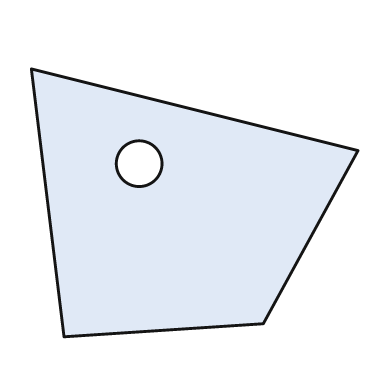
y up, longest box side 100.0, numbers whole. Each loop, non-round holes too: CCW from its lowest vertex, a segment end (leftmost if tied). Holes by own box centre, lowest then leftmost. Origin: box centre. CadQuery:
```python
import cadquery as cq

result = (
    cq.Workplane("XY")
    .moveTo(-40.0, -41.0)
    .lineTo(21.0, -37.0)
    .lineTo(50.0, 16.0)
    .lineTo(-50.0, 41.0)
    .close()
    .moveTo(-17.0, 12.0)
    .circle(7.0)
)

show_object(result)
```